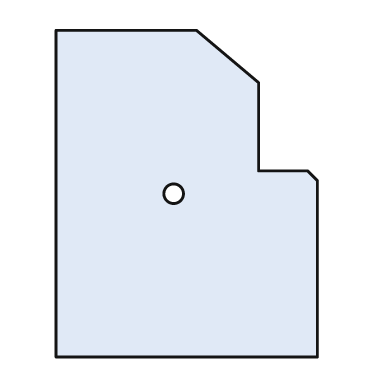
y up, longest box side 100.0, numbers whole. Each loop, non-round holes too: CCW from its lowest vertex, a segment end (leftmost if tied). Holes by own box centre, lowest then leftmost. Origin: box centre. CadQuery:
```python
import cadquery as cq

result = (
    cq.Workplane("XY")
    .moveTo(-40.0, -50.0)
    .lineTo(40.0, -50.0)
    .lineTo(40.0, 4.0)
    .lineTo(37.0, 7.0)
    .lineTo(22.0, 7.0)
    .lineTo(22.0, 34.0)
    .lineTo(3.0, 50.0)
    .lineTo(-40.0, 50.0)
    .close()
    .moveTo(-4.0, 0.0)
    .circle(3.0)
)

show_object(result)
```